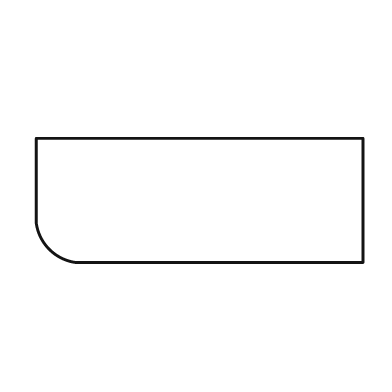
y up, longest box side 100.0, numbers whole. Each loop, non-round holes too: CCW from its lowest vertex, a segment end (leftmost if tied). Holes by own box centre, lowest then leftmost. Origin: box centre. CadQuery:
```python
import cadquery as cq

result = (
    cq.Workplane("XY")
    .moveTo(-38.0, -19.0)
    .lineTo(50.0, -19.0)
    .lineTo(50.0, 19.0)
    .lineTo(-50.0, 19.0)
    .lineTo(-50.0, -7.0)
    .threePointArc((-46.0, -15.0), (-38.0, -19.0))
    .close()
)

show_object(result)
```